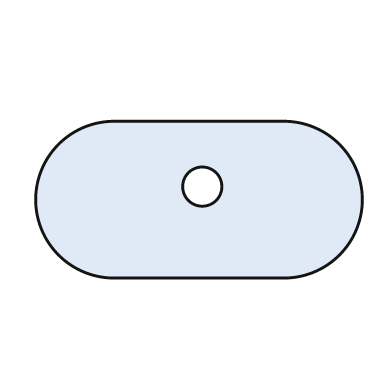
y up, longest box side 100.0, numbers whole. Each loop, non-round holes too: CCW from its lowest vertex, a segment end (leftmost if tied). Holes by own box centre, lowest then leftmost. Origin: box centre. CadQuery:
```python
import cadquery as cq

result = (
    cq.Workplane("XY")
    .moveTo(-26.0, -24.0)
    .lineTo(26.0, -24.0)
    .threePointArc((50.0, 0.0), (26.0, 24.0))
    .lineTo(-26.0, 24.0)
    .threePointArc((-50.0, 0.0), (-26.0, -24.0))
    .close()
    .moveTo(1.0, 4.0)
    .circle(6.0)
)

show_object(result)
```